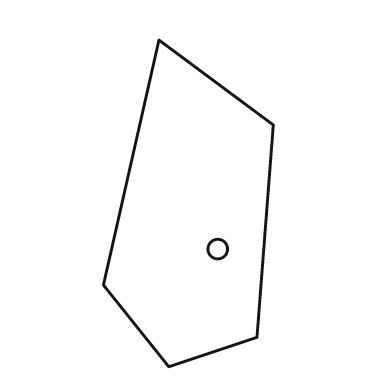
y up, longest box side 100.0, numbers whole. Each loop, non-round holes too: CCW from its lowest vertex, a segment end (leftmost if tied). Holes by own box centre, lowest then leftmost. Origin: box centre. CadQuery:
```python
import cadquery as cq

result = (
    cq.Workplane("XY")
    .moveTo(-6.0, -50.0)
    .lineTo(21.0, -41.0)
    .lineTo(26.0, 24.0)
    .lineTo(-9.0, 50.0)
    .lineTo(-26.0, -25.0)
    .close()
    .moveTo(9.0, -14.0)
    .circle(3.0)
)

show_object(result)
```